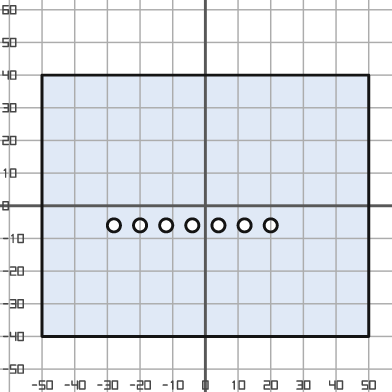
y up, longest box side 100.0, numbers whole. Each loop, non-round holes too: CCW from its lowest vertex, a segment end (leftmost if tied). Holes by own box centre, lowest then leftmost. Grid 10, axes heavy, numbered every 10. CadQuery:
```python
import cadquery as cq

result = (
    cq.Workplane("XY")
    .moveTo(-50.0, -40.0)
    .lineTo(50.0, -40.0)
    .lineTo(50.0, 40.0)
    .lineTo(-50.0, 40.0)
    .close()
    .moveTo(-28.0, -6.0)
    .circle(2.0)
    .moveTo(-20.0, -6.0)
    .circle(2.0)
    .moveTo(-12.0, -6.0)
    .circle(2.0)
    .moveTo(-4.0, -6.0)
    .circle(2.0)
    .moveTo(4.0, -6.0)
    .circle(2.0)
    .moveTo(12.0, -6.0)
    .circle(2.0)
    .moveTo(20.0, -6.0)
    .circle(2.0)
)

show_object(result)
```